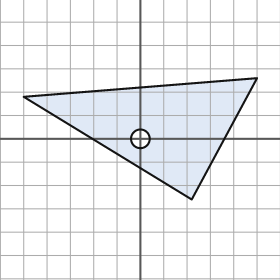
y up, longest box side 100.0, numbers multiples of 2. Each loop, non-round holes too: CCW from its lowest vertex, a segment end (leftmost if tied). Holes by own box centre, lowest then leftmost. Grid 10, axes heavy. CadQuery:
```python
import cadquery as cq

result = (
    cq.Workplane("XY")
    .moveTo(22.0, -26.0)
    .lineTo(50.0, 26.0)
    .lineTo(-50.0, 18.0)
    .close()
    .moveTo(0.0, 0.0)
    .circle(4.0)
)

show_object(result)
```